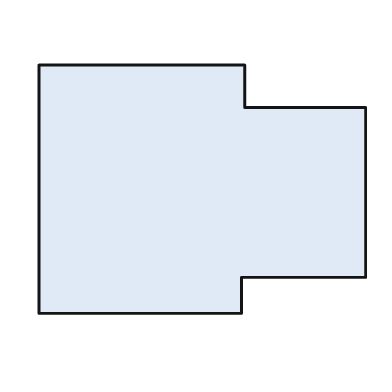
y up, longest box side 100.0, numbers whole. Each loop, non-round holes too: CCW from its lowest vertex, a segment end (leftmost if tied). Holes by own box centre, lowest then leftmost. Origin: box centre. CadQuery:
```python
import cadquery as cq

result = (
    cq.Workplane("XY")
    .moveTo(-50.0, -38.0)
    .lineTo(12.0, -38.0)
    .lineTo(12.0, -27.0)
    .lineTo(50.0, -27.0)
    .lineTo(50.0, 25.0)
    .lineTo(13.0, 25.0)
    .lineTo(13.0, 38.0)
    .lineTo(-50.0, 38.0)
    .close()
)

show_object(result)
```